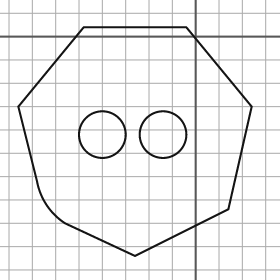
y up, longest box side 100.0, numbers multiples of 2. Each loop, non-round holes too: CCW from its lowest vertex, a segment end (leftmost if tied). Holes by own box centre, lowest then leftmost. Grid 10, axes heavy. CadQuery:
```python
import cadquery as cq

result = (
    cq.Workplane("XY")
    .moveTo(-26.0, -94.0)
    .lineTo(14.0, -74.0)
    .lineTo(24.0, -30.0)
    .lineTo(-4.0, 4.0)
    .lineTo(-48.0, 4.0)
    .lineTo(-76.0, -30.0)
    .lineTo(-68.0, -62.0)
    .threePointArc((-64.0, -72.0), (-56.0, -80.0))
    .close()
    .moveTo(-40.0, -42.0)
    .circle(10.0)
    .moveTo(-14.0, -42.0)
    .circle(10.0)
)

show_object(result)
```